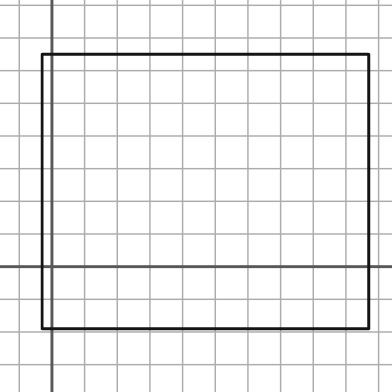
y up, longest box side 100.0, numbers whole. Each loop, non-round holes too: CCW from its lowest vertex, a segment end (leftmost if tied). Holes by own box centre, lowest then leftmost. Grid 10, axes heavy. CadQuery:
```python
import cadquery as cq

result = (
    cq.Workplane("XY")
    .moveTo(-3.0, -19.0)
    .lineTo(97.0, -19.0)
    .lineTo(97.0, 65.0)
    .lineTo(-3.0, 65.0)
    .close()
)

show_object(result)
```